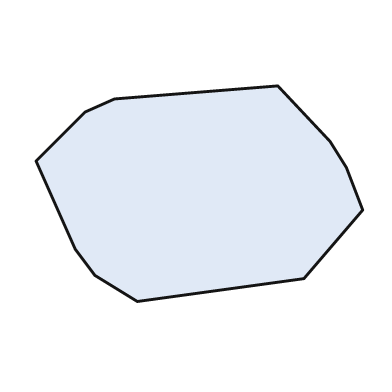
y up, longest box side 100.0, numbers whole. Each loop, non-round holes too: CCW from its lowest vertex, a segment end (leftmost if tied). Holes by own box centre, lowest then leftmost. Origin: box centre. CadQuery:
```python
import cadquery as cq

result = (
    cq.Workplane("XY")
    .moveTo(-19.0, -33.0)
    .lineTo(32.0, -26.0)
    .lineTo(50.0, -5.0)
    .lineTo(45.0, 8.0)
    .lineTo(40.0, 16.0)
    .lineTo(24.0, 33.0)
    .lineTo(-26.0, 29.0)
    .lineTo(-35.0, 25.0)
    .lineTo(-50.0, 10.0)
    .lineTo(-38.0, -17.0)
    .lineTo(-32.0, -25.0)
    .close()
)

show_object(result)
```